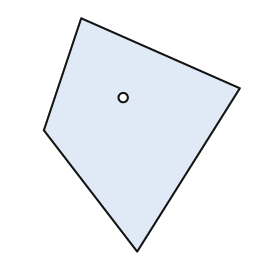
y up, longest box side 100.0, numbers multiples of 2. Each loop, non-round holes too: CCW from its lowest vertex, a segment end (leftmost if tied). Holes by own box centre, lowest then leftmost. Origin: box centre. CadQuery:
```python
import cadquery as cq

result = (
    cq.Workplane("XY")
    .moveTo(-2.0, -50.0)
    .lineTo(42.0, 20.0)
    .lineTo(-26.0, 50.0)
    .lineTo(-42.0, 2.0)
    .close()
    .moveTo(-8.0, 16.0)
    .circle(2.0)
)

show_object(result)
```